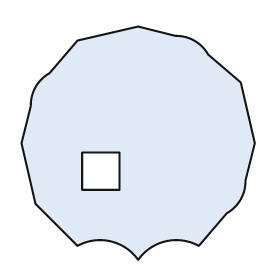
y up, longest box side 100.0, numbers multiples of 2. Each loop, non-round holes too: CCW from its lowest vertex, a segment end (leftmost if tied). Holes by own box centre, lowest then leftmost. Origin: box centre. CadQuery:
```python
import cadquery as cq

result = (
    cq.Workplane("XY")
    .moveTo(0.0, -50.0)
    .threePointArc((12.0, -42.0), (26.0, -44.0))
    .lineTo(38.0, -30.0)
    .threePointArc((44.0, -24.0), (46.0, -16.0))
    .lineTo(50.0, 0.0)
    .lineTo(44.0, 26.0)
    .lineTo(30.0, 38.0)
    .threePointArc((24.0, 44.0), (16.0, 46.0))
    .lineTo(0.0, 50.0)
    .lineTo(-26.0, 44.0)
    .lineTo(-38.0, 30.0)
    .threePointArc((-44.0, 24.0), (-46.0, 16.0))
    .lineTo(-50.0, 0.0)
    .lineTo(-44.0, -26.0)
    .lineTo(-26.0, -44.0)
    .threePointArc((-12.0, -42.0), (0.0, -50.0))
    .close()
    .moveTo(-24.0, -20.0)
    .lineTo(-8.0, -20.0)
    .lineTo(-8.0, -4.0)
    .lineTo(-24.0, -4.0)
    .close()
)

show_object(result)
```